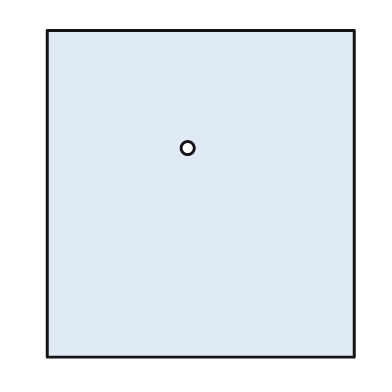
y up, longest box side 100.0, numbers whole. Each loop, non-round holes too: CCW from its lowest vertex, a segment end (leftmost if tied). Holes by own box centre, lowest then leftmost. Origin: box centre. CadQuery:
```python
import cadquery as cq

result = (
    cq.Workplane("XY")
    .moveTo(-47.0, -50.0)
    .lineTo(47.0, -50.0)
    .lineTo(47.0, 50.0)
    .lineTo(-47.0, 50.0)
    .close()
    .moveTo(-4.0, 14.0)
    .circle(2.0)
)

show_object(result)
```